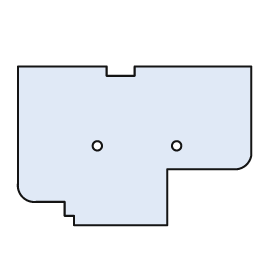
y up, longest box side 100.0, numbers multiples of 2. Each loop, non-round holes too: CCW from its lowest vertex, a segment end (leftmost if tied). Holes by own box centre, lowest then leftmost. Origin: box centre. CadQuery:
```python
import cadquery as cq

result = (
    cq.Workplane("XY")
    .moveTo(-26.0, -34.0)
    .lineTo(14.0, -34.0)
    .lineTo(14.0, -10.0)
    .lineTo(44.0, -10.0)
    .threePointArc((48.0, -8.0), (50.0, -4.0))
    .lineTo(50.0, 34.0)
    .lineTo(0.0, 34.0)
    .lineTo(0.0, 30.0)
    .lineTo(-12.0, 30.0)
    .lineTo(-12.0, 34.0)
    .lineTo(-50.0, 34.0)
    .lineTo(-50.0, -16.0)
    .threePointArc((-48.0, -22.0), (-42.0, -24.0))
    .lineTo(-30.0, -24.0)
    .lineTo(-30.0, -30.0)
    .lineTo(-26.0, -30.0)
    .close()
    .moveTo(-16.0, 0.0)
    .circle(2.0)
    .moveTo(18.0, 0.0)
    .circle(2.0)
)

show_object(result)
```